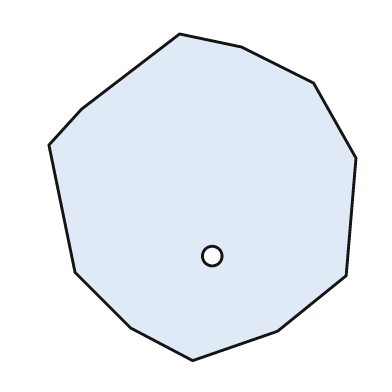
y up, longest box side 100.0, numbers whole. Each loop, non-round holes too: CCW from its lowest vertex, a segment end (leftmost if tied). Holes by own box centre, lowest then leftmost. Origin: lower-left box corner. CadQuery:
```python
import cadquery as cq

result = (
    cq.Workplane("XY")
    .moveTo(44.0, 0.0)
    .lineTo(70.0, 9.0)
    .lineTo(91.0, 26.0)
    .lineTo(94.0, 62.0)
    .lineTo(81.0, 85.0)
    .lineTo(59.0, 96.0)
    .lineTo(40.0, 100.0)
    .lineTo(10.0, 77.0)
    .lineTo(0.0, 66.0)
    .lineTo(8.0, 27.0)
    .lineTo(25.0, 10.0)
    .close()
    .moveTo(50.0, 32.0)
    .circle(3.0)
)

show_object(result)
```